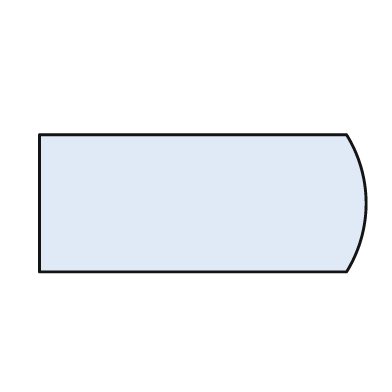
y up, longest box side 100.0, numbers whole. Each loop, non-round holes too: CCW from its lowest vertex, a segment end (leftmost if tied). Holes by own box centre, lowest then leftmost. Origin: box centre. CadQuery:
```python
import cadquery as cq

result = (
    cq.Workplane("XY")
    .moveTo(-50.0, -21.0)
    .lineTo(44.0, -21.0)
    .threePointArc((50.0, 0.0), (44.0, 21.0))
    .lineTo(-50.0, 21.0)
    .close()
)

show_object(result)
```